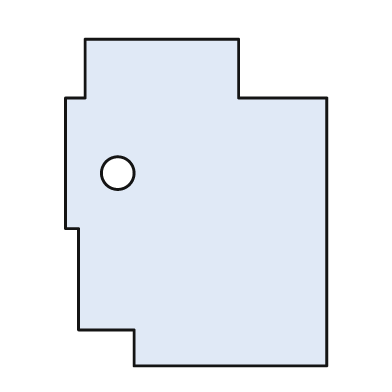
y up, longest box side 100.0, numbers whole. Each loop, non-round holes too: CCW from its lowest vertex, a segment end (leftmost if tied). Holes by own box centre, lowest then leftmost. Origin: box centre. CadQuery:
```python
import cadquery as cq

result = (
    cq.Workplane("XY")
    .moveTo(-19.0, -50.0)
    .lineTo(40.0, -50.0)
    .lineTo(40.0, 32.0)
    .lineTo(13.0, 32.0)
    .lineTo(13.0, 50.0)
    .lineTo(-34.0, 50.0)
    .lineTo(-34.0, 32.0)
    .lineTo(-40.0, 32.0)
    .lineTo(-40.0, -8.0)
    .lineTo(-36.0, -8.0)
    .lineTo(-36.0, -39.0)
    .lineTo(-19.0, -39.0)
    .close()
    .moveTo(-24.0, 9.0)
    .circle(5.0)
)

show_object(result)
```